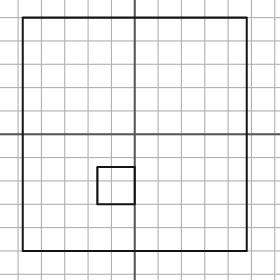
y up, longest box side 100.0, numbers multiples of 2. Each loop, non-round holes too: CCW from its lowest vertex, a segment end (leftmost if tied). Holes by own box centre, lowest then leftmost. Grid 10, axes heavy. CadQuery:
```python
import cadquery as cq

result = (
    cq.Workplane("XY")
    .moveTo(-48.0, -50.0)
    .lineTo(48.0, -50.0)
    .lineTo(48.0, 50.0)
    .lineTo(-48.0, 50.0)
    .close()
    .moveTo(-16.0, -30.0)
    .lineTo(0.0, -30.0)
    .lineTo(0.0, -14.0)
    .lineTo(-16.0, -14.0)
    .close()
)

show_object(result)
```